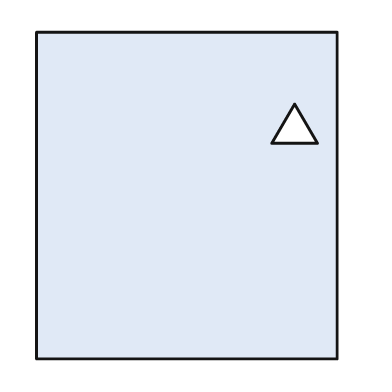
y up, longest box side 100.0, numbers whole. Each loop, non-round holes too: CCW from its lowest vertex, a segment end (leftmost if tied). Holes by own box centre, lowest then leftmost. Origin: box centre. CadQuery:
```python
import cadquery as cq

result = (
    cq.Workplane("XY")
    .moveTo(-46.0, -50.0)
    .lineTo(46.0, -50.0)
    .lineTo(46.0, 50.0)
    .lineTo(-46.0, 50.0)
    .close()
    .moveTo(26.0, 16.0)
    .lineTo(40.0, 16.0)
    .lineTo(33.0, 28.0)
    .close()
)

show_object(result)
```